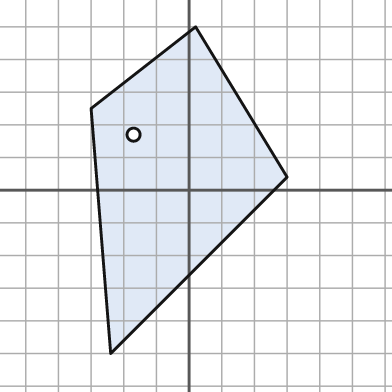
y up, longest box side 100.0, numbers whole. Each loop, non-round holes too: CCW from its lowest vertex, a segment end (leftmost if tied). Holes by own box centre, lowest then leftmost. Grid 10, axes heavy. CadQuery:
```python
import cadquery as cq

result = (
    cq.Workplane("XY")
    .moveTo(-24.0, -50.0)
    .lineTo(30.0, 4.0)
    .lineTo(2.0, 50.0)
    .lineTo(-30.0, 25.0)
    .close()
    .moveTo(-17.0, 17.0)
    .circle(2.0)
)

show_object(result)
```